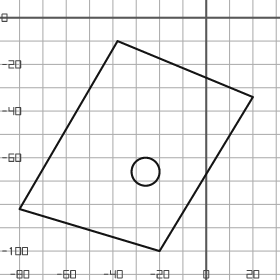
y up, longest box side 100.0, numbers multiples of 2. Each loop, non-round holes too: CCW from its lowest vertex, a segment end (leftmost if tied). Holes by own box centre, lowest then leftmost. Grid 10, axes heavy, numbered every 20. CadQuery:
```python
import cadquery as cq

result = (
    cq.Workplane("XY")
    .moveTo(-20.0, -100.0)
    .lineTo(20.0, -34.0)
    .lineTo(-38.0, -10.0)
    .lineTo(-80.0, -82.0)
    .close()
    .moveTo(-26.0, -66.0)
    .circle(6.0)
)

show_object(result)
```